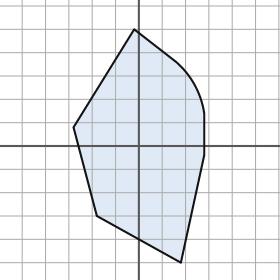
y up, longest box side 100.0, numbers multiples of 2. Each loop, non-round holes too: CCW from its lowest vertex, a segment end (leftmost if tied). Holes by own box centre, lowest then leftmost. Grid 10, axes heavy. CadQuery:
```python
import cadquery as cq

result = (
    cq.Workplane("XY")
    .moveTo(18.0, -50.0)
    .lineTo(28.0, -4.0)
    .lineTo(28.0, 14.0)
    .threePointArc((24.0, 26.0), (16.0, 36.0))
    .lineTo(-2.0, 50.0)
    .lineTo(-28.0, 8.0)
    .lineTo(-18.0, -30.0)
    .close()
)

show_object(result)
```